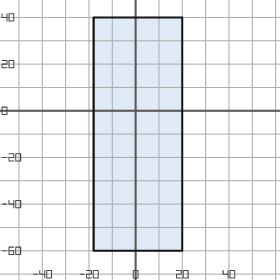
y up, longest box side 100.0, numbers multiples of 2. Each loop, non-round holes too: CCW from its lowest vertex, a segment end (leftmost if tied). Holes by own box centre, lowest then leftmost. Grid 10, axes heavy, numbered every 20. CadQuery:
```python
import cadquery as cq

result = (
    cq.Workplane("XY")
    .moveTo(-18.0, -60.0)
    .lineTo(20.0, -60.0)
    .lineTo(20.0, 40.0)
    .lineTo(-18.0, 40.0)
    .close()
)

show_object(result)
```